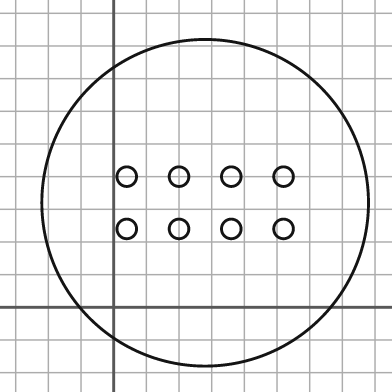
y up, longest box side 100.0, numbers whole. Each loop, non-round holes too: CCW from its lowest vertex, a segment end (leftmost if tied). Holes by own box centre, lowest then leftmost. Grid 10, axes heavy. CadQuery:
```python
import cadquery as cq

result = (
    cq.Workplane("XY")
    .moveTo(28.0, 32.0)
    .circle(50.0)
    .moveTo(4.0, 24.0)
    .circle(3.0)
    .moveTo(20.0, 24.0)
    .circle(3.0)
    .moveTo(36.0, 24.0)
    .circle(3.0)
    .moveTo(52.0, 24.0)
    .circle(3.0)
    .moveTo(4.0, 40.0)
    .circle(3.0)
    .moveTo(20.0, 40.0)
    .circle(3.0)
    .moveTo(36.0, 40.0)
    .circle(3.0)
    .moveTo(52.0, 40.0)
    .circle(3.0)
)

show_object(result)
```